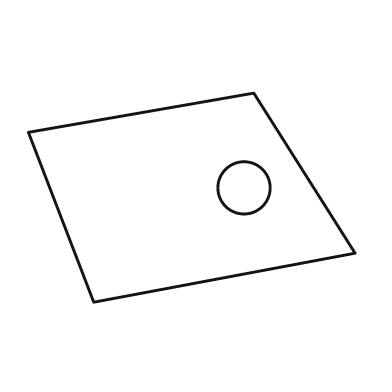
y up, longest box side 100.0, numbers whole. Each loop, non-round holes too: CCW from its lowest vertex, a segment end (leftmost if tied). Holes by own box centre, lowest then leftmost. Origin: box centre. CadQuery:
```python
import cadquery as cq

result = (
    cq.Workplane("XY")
    .moveTo(-30.0, -32.0)
    .lineTo(50.0, -17.0)
    .lineTo(19.0, 32.0)
    .lineTo(-50.0, 20.0)
    .close()
    .moveTo(16.0, 3.0)
    .circle(8.0)
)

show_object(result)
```